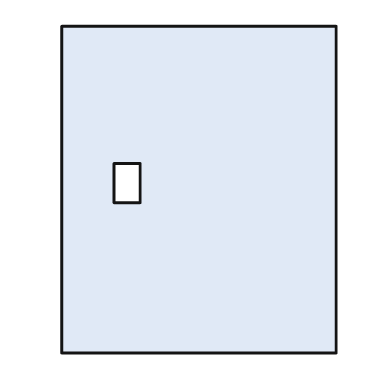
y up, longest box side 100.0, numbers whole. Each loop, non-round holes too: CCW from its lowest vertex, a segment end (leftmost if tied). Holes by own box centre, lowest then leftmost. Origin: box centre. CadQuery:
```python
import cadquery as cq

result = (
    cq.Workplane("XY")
    .moveTo(-42.0, -50.0)
    .lineTo(42.0, -50.0)
    .lineTo(42.0, 50.0)
    .lineTo(-42.0, 50.0)
    .close()
    .moveTo(-26.0, -4.0)
    .lineTo(-18.0, -4.0)
    .lineTo(-18.0, 8.0)
    .lineTo(-26.0, 8.0)
    .close()
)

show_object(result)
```